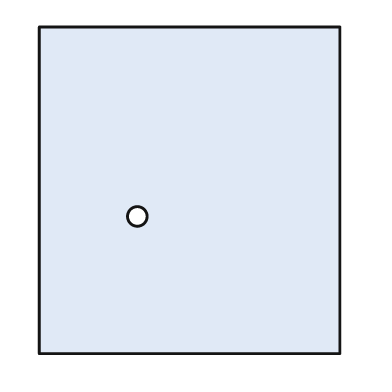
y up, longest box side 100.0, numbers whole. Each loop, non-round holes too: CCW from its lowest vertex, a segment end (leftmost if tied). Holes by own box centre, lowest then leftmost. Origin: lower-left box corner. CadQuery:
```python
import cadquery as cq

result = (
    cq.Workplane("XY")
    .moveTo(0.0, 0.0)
    .lineTo(92.0, 0.0)
    .lineTo(92.0, 100.0)
    .lineTo(0.0, 100.0)
    .close()
    .moveTo(30.0, 42.0)
    .circle(3.0)
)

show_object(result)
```